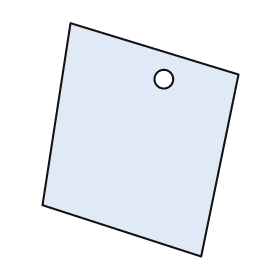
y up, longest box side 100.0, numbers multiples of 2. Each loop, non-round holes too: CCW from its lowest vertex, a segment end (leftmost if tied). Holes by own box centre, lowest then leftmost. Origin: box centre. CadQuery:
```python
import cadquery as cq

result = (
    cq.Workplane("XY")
    .moveTo(26.0, -50.0)
    .lineTo(42.0, 28.0)
    .lineTo(-30.0, 50.0)
    .lineTo(-42.0, -28.0)
    .close()
    .moveTo(10.0, 26.0)
    .circle(4.0)
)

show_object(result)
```